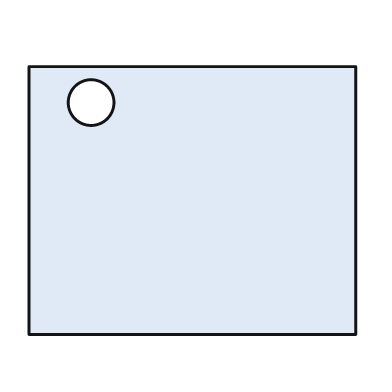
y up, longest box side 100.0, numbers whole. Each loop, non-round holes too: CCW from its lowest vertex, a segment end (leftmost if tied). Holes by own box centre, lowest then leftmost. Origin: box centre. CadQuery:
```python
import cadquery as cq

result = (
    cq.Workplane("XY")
    .moveTo(-50.0, -41.0)
    .lineTo(50.0, -41.0)
    .lineTo(50.0, 41.0)
    .lineTo(-50.0, 41.0)
    .close()
    .moveTo(-31.0, 30.0)
    .circle(7.0)
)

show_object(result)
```